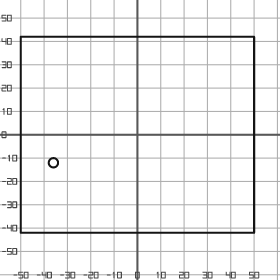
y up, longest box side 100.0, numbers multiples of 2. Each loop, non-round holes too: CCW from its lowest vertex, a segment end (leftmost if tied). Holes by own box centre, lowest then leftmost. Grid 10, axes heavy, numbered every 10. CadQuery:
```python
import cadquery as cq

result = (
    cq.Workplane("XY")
    .moveTo(-50.0, -42.0)
    .lineTo(50.0, -42.0)
    .lineTo(50.0, 42.0)
    .lineTo(-50.0, 42.0)
    .close()
    .moveTo(-36.0, -12.0)
    .circle(2.0)
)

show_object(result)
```